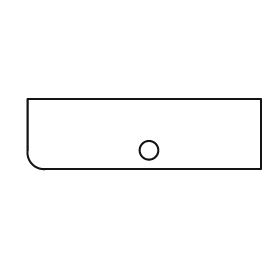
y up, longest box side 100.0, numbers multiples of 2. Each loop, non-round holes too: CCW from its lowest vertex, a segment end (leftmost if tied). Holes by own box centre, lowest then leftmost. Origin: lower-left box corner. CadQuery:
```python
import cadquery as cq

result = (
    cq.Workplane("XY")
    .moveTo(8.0, 0.0)
    .lineTo(100.0, 0.0)
    .lineTo(100.0, 30.0)
    .lineTo(0.0, 30.0)
    .lineTo(0.0, 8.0)
    .threePointArc((2.0, 2.0), (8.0, 0.0))
    .close()
    .moveTo(52.0, 8.0)
    .circle(4.0)
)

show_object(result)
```